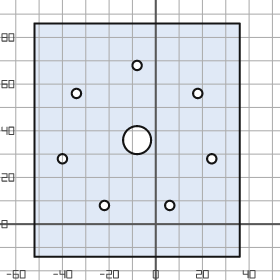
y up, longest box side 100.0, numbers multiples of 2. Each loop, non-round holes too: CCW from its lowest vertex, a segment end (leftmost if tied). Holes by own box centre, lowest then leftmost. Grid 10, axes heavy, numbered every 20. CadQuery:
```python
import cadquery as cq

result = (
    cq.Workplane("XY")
    .moveTo(-52.0, -14.0)
    .lineTo(36.0, -14.0)
    .lineTo(36.0, 86.0)
    .lineTo(-52.0, 86.0)
    .close()
    .moveTo(-22.0, 8.0)
    .circle(2.0)
    .moveTo(6.0, 8.0)
    .circle(2.0)
    .moveTo(-40.0, 28.0)
    .circle(2.0)
    .moveTo(24.0, 28.0)
    .circle(2.0)
    .moveTo(-8.0, 36.0)
    .circle(6.0)
    .moveTo(-34.0, 56.0)
    .circle(2.0)
    .moveTo(18.0, 56.0)
    .circle(2.0)
    .moveTo(-8.0, 68.0)
    .circle(2.0)
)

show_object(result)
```